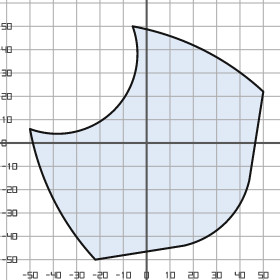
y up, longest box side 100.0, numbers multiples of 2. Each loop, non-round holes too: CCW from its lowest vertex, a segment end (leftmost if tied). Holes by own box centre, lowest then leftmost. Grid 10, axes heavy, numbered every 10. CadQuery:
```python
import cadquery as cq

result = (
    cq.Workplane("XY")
    .moveTo(-22.0, -50.0)
    .lineTo(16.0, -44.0)
    .threePointArc((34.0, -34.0), (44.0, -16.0))
    .lineTo(50.0, 22.0)
    .threePointArc((24.0, 40.0), (-6.0, 50.0))
    .threePointArc((-14.0, 14.0), (-50.0, 6.0))
    .threePointArc((-40.0, -24.0), (-22.0, -50.0))
    .close()
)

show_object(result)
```